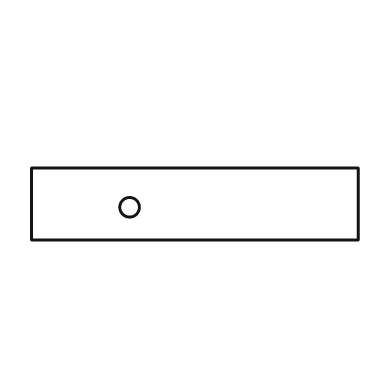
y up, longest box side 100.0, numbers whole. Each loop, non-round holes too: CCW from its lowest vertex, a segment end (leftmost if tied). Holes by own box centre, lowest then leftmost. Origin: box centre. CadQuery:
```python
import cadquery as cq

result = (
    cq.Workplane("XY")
    .moveTo(-50.0, -11.0)
    .lineTo(50.0, -11.0)
    .lineTo(50.0, 11.0)
    .lineTo(-50.0, 11.0)
    .close()
    .moveTo(-20.0, -1.0)
    .circle(3.0)
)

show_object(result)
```